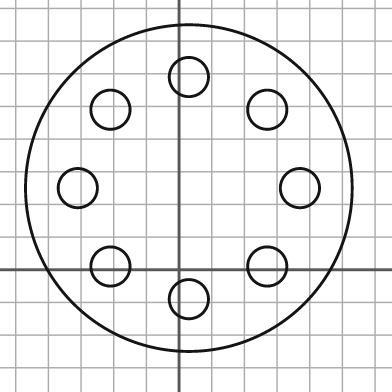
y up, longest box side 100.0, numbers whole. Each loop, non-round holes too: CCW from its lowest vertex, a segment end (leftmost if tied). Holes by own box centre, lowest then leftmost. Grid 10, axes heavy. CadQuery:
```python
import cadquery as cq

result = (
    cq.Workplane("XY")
    .moveTo(3.0, 25.0)
    .circle(50.0)
    .moveTo(3.0, -9.0)
    .circle(6.0)
    .moveTo(-21.0, 1.0)
    .circle(6.0)
    .moveTo(27.0, 1.0)
    .circle(6.0)
    .moveTo(-31.0, 25.0)
    .circle(6.0)
    .moveTo(37.0, 25.0)
    .circle(6.0)
    .moveTo(-21.0, 49.0)
    .circle(6.0)
    .moveTo(27.0, 49.0)
    .circle(6.0)
    .moveTo(3.0, 59.0)
    .circle(6.0)
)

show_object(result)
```